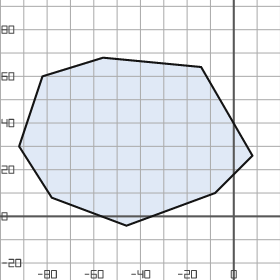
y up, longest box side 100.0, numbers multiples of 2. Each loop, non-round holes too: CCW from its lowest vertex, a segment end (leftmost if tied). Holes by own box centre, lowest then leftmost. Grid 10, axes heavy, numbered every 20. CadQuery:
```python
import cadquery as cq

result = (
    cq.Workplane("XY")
    .moveTo(-46.0, -4.0)
    .lineTo(-8.0, 10.0)
    .lineTo(8.0, 26.0)
    .lineTo(-14.0, 64.0)
    .lineTo(-56.0, 68.0)
    .lineTo(-82.0, 60.0)
    .lineTo(-92.0, 30.0)
    .lineTo(-78.0, 8.0)
    .close()
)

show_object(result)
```